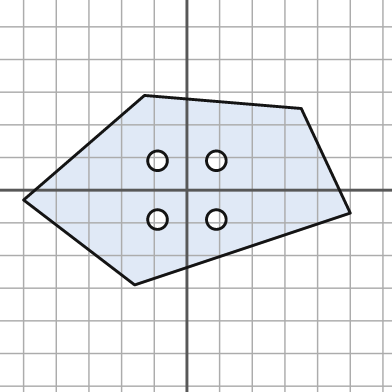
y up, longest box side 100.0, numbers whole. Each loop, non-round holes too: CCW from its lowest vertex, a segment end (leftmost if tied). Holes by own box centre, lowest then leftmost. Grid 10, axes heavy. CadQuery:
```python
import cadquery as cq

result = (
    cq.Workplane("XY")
    .moveTo(-16.0, -29.0)
    .lineTo(50.0, -7.0)
    .lineTo(35.0, 25.0)
    .lineTo(-13.0, 29.0)
    .lineTo(-50.0, -3.0)
    .close()
    .moveTo(-9.0, -9.0)
    .circle(3.0)
    .moveTo(9.0, -9.0)
    .circle(3.0)
    .moveTo(-9.0, 9.0)
    .circle(3.0)
    .moveTo(9.0, 9.0)
    .circle(3.0)
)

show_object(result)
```